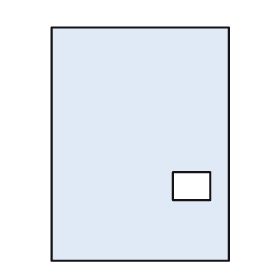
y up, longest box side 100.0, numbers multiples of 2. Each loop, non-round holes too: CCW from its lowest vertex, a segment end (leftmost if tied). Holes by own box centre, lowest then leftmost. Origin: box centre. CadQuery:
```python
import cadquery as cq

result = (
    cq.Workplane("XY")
    .moveTo(-38.0, -50.0)
    .lineTo(38.0, -50.0)
    .lineTo(38.0, 50.0)
    .lineTo(-38.0, 50.0)
    .close()
    .moveTo(14.0, -24.0)
    .lineTo(30.0, -24.0)
    .lineTo(30.0, -12.0)
    .lineTo(14.0, -12.0)
    .close()
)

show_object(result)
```